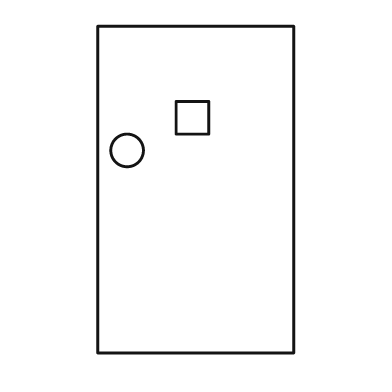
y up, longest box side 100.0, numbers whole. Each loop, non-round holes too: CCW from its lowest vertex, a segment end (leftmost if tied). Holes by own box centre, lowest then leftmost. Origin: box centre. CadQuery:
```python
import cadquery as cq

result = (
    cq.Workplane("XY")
    .moveTo(-30.0, -50.0)
    .lineTo(30.0, -50.0)
    .lineTo(30.0, 50.0)
    .lineTo(-30.0, 50.0)
    .close()
    .moveTo(-21.0, 12.0)
    .circle(5.0)
    .moveTo(-6.0, 17.0)
    .lineTo(4.0, 17.0)
    .lineTo(4.0, 27.0)
    .lineTo(-6.0, 27.0)
    .close()
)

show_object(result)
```